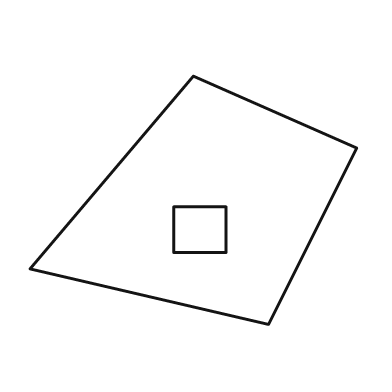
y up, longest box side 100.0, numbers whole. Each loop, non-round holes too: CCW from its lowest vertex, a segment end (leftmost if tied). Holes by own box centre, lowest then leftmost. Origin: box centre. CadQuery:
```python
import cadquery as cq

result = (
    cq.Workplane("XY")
    .moveTo(23.0, -38.0)
    .lineTo(50.0, 16.0)
    .lineTo(0.0, 38.0)
    .lineTo(-50.0, -21.0)
    .close()
    .moveTo(-6.0, -16.0)
    .lineTo(10.0, -16.0)
    .lineTo(10.0, -2.0)
    .lineTo(-6.0, -2.0)
    .close()
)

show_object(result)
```